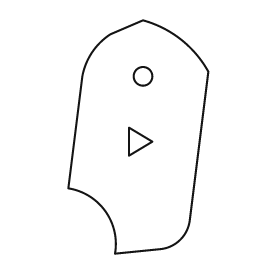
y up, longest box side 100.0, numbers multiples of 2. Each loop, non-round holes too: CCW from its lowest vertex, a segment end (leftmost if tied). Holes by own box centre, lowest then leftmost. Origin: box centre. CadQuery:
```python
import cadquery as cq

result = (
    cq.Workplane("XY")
    .moveTo(-10.0, -50.0)
    .lineTo(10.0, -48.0)
    .threePointArc((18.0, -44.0), (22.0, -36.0))
    .lineTo(30.0, 28.0)
    .threePointArc((18.0, 42.0), (2.0, 50.0))
    .lineTo(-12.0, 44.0)
    .threePointArc((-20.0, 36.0), (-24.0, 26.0))
    .lineTo(-30.0, -22.0)
    .threePointArc((-14.0, -32.0), (-10.0, -50.0))
    .close()
    .moveTo(-4.0, -8.0)
    .lineTo(6.0, -2.0)
    .lineTo(-4.0, 4.0)
    .close()
    .moveTo(2.0, 26.0)
    .circle(4.0)
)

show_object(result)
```